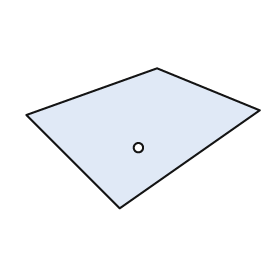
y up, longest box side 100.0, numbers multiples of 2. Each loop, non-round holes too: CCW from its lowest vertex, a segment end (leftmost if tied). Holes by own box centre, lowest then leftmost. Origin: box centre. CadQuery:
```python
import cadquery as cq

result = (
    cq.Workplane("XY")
    .moveTo(-10.0, -30.0)
    .lineTo(50.0, 12.0)
    .lineTo(6.0, 30.0)
    .lineTo(-50.0, 10.0)
    .close()
    .moveTo(-2.0, -4.0)
    .circle(2.0)
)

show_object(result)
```